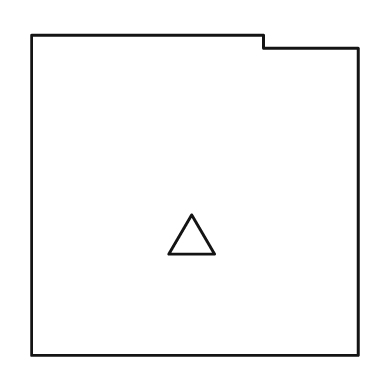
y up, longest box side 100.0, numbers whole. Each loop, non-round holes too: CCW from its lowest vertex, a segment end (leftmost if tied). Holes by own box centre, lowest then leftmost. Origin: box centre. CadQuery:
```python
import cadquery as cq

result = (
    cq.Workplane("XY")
    .moveTo(-50.0, -49.0)
    .lineTo(50.0, -49.0)
    .lineTo(50.0, 45.0)
    .lineTo(21.0, 45.0)
    .lineTo(21.0, 49.0)
    .lineTo(-50.0, 49.0)
    .close()
    .moveTo(-8.0, -18.0)
    .lineTo(6.0, -18.0)
    .lineTo(-1.0, -6.0)
    .close()
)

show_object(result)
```